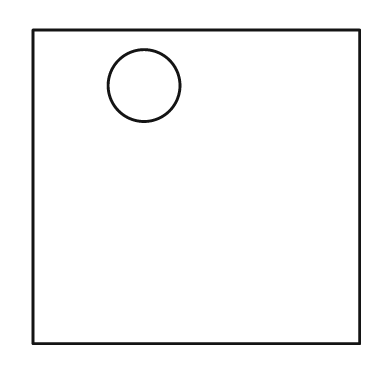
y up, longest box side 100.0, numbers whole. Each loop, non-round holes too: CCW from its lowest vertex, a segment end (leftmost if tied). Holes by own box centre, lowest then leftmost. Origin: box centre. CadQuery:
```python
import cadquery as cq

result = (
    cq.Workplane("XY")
    .moveTo(-50.0, -48.0)
    .lineTo(50.0, -48.0)
    .lineTo(50.0, 48.0)
    .lineTo(-50.0, 48.0)
    .close()
    .moveTo(-16.0, 31.0)
    .circle(11.0)
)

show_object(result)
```